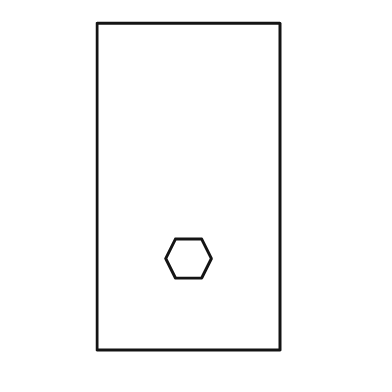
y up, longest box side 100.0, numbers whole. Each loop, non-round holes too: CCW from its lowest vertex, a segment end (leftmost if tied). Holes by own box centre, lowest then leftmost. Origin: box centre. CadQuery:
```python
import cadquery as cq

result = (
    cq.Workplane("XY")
    .moveTo(-28.0, -50.0)
    .lineTo(28.0, -50.0)
    .lineTo(28.0, 50.0)
    .lineTo(-28.0, 50.0)
    .close()
    .moveTo(-4.0, -28.0)
    .lineTo(4.0, -28.0)
    .lineTo(7.0, -22.0)
    .lineTo(4.0, -16.0)
    .lineTo(-4.0, -16.0)
    .lineTo(-7.0, -22.0)
    .close()
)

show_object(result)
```